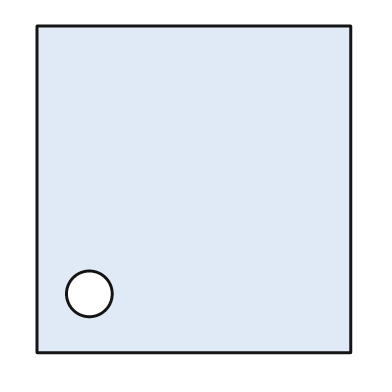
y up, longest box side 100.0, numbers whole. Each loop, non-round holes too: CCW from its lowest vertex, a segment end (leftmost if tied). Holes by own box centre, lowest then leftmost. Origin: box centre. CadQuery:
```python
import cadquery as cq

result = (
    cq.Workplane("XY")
    .moveTo(-48.0, -50.0)
    .lineTo(48.0, -50.0)
    .lineTo(48.0, 50.0)
    .lineTo(-48.0, 50.0)
    .close()
    .moveTo(-32.0, -32.0)
    .circle(7.0)
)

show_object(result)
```